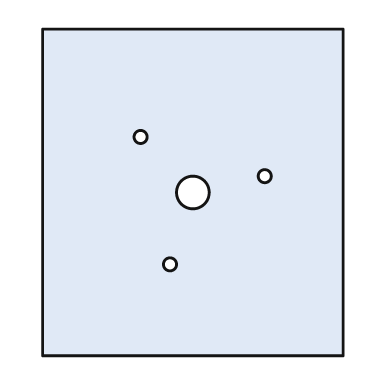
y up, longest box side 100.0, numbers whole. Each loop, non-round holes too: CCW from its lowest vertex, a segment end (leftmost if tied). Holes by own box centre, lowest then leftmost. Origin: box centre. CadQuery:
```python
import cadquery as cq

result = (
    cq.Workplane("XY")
    .moveTo(-46.0, -50.0)
    .lineTo(46.0, -50.0)
    .lineTo(46.0, 50.0)
    .lineTo(-46.0, 50.0)
    .close()
    .moveTo(-7.0, -22.0)
    .circle(2.0)
    .moveTo(0.0, 0.0)
    .circle(5.0)
    .moveTo(22.0, 5.0)
    .circle(2.0)
    .moveTo(-16.0, 17.0)
    .circle(2.0)
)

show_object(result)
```